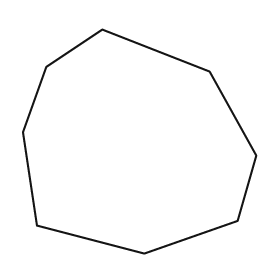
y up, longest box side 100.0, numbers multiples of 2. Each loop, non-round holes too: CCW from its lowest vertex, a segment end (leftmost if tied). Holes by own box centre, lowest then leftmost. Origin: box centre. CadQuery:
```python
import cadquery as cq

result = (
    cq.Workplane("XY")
    .moveTo(2.0, -48.0)
    .lineTo(42.0, -34.0)
    .lineTo(50.0, -6.0)
    .lineTo(30.0, 30.0)
    .lineTo(-16.0, 48.0)
    .lineTo(-40.0, 32.0)
    .lineTo(-50.0, 4.0)
    .lineTo(-44.0, -36.0)
    .close()
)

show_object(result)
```